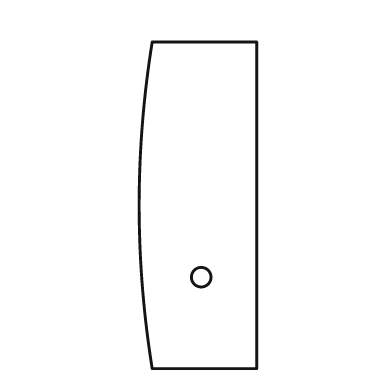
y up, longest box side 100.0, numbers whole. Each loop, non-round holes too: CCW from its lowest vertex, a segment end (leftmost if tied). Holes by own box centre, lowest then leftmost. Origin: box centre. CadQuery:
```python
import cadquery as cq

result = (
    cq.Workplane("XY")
    .moveTo(-14.0, -50.0)
    .lineTo(18.0, -50.0)
    .lineTo(18.0, 50.0)
    .lineTo(-14.0, 50.0)
    .threePointArc((-18.0, 0.0), (-14.0, -50.0))
    .close()
    .moveTo(1.0, -22.0)
    .circle(3.0)
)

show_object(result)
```